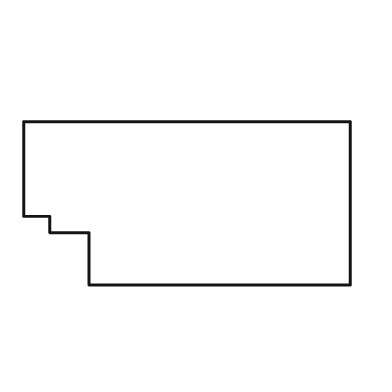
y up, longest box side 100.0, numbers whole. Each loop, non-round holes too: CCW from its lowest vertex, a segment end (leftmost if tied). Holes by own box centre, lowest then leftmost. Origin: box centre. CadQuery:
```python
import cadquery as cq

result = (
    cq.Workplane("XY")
    .moveTo(-30.0, -25.0)
    .lineTo(50.0, -25.0)
    .lineTo(50.0, 25.0)
    .lineTo(-50.0, 25.0)
    .lineTo(-50.0, -4.0)
    .lineTo(-42.0, -4.0)
    .lineTo(-42.0, -9.0)
    .lineTo(-30.0, -9.0)
    .close()
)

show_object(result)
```